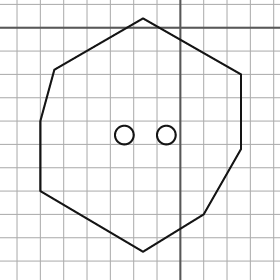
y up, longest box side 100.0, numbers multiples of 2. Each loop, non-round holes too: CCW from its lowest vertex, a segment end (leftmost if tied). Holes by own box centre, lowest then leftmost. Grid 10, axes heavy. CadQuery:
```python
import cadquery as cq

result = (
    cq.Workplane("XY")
    .moveTo(-16.0, -96.0)
    .lineTo(10.0, -80.0)
    .lineTo(26.0, -52.0)
    .lineTo(26.0, -20.0)
    .lineTo(-16.0, 4.0)
    .lineTo(-54.0, -18.0)
    .lineTo(-60.0, -40.0)
    .lineTo(-60.0, -70.0)
    .close()
    .moveTo(-24.0, -46.0)
    .circle(4.0)
    .moveTo(-6.0, -46.0)
    .circle(4.0)
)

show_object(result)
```